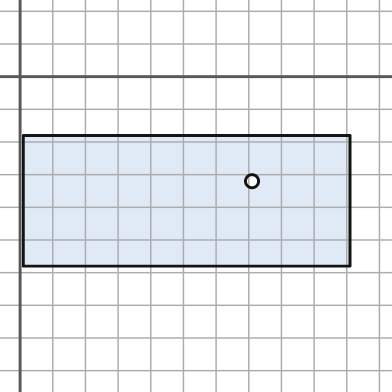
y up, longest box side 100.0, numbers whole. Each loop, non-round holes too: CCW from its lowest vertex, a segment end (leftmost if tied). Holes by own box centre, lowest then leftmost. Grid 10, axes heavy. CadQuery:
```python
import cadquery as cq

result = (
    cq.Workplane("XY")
    .moveTo(1.0, -58.0)
    .lineTo(101.0, -58.0)
    .lineTo(101.0, -18.0)
    .lineTo(1.0, -18.0)
    .close()
    .moveTo(71.0, -32.0)
    .circle(2.0)
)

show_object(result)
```